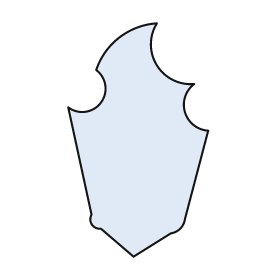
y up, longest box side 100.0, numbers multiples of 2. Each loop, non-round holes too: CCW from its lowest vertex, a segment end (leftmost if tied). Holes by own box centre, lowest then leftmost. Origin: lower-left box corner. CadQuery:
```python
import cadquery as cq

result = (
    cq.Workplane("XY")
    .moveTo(28.0, 0.0)
    .lineTo(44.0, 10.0)
    .threePointArc((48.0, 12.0), (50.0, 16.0))
    .lineTo(60.0, 54.0)
    .threePointArc((50.0, 62.0), (54.0, 74.0))
    .threePointArc((38.0, 82.0), (38.0, 100.0))
    .threePointArc((22.0, 94.0), (12.0, 80.0))
    .threePointArc((14.0, 66.0), (0.0, 64.0))
    .lineTo(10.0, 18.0)
    .threePointArc((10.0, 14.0), (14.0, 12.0))
    .close()
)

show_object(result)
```